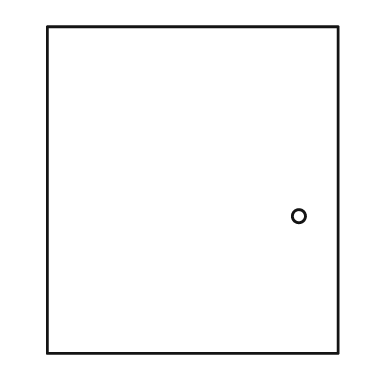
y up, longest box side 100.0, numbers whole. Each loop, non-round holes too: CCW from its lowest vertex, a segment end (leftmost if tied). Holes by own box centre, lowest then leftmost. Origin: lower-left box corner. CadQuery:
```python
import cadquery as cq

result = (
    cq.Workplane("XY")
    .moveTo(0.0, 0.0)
    .lineTo(89.0, 0.0)
    .lineTo(89.0, 100.0)
    .lineTo(0.0, 100.0)
    .close()
    .moveTo(77.0, 42.0)
    .circle(2.0)
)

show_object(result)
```